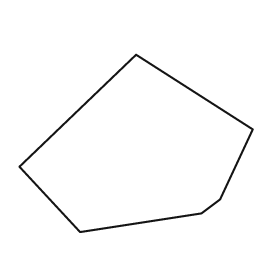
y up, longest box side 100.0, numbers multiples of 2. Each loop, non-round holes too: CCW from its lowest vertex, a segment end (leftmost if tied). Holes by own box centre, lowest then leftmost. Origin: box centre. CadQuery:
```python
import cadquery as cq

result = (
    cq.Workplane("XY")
    .moveTo(-24.0, -38.0)
    .lineTo(28.0, -30.0)
    .lineTo(36.0, -24.0)
    .lineTo(50.0, 6.0)
    .lineTo(0.0, 38.0)
    .lineTo(-50.0, -10.0)
    .close()
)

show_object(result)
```